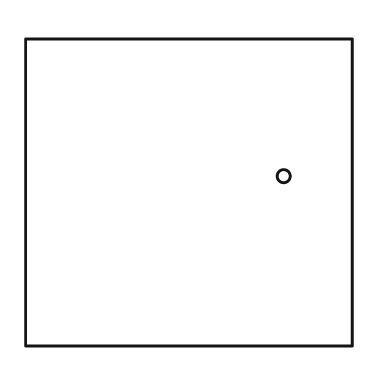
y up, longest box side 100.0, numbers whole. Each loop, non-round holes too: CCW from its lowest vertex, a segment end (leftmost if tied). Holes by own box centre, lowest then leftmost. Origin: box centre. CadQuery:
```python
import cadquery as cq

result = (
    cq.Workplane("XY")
    .moveTo(-50.0, -47.0)
    .lineTo(50.0, -47.0)
    .lineTo(50.0, 47.0)
    .lineTo(-50.0, 47.0)
    .close()
    .moveTo(29.0, 5.0)
    .circle(2.0)
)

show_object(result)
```